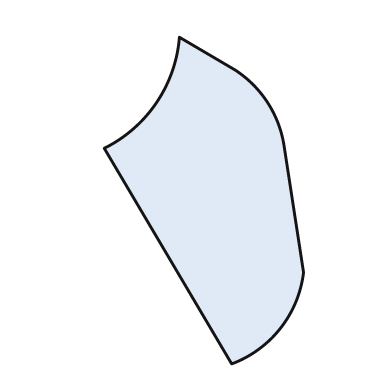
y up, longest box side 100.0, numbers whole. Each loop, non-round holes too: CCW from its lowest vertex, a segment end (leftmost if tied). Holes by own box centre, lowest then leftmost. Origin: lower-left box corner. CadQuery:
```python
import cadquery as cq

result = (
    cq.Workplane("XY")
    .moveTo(39.0, 0.0)
    .threePointArc((54.0, 11.0), (61.0, 28.0))
    .lineTo(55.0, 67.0)
    .threePointArc((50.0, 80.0), (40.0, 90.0))
    .lineTo(23.0, 100.0)
    .threePointArc((16.0, 80.0), (0.0, 66.0))
    .close()
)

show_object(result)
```